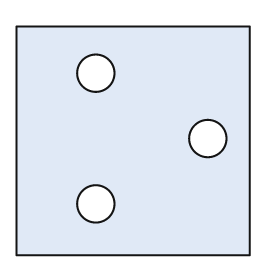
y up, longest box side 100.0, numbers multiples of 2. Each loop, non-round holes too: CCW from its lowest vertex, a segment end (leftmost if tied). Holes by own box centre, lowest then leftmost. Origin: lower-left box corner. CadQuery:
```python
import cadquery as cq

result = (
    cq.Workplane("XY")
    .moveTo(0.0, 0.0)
    .lineTo(100.0, 0.0)
    .lineTo(100.0, 98.0)
    .lineTo(0.0, 98.0)
    .close()
    .moveTo(34.0, 22.0)
    .circle(8.0)
    .moveTo(82.0, 50.0)
    .circle(8.0)
    .moveTo(34.0, 78.0)
    .circle(8.0)
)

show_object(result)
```